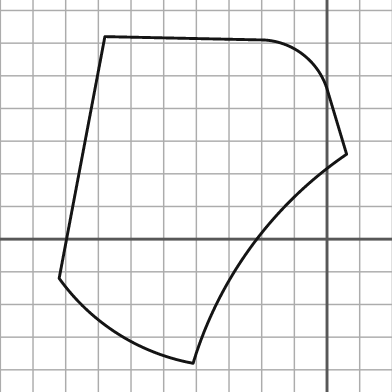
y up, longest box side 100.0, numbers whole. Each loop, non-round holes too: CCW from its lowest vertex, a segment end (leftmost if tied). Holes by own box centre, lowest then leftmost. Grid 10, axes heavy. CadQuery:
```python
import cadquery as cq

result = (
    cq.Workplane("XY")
    .moveTo(-41.0, -38.0)
    .threePointArc((-23.0, -2.0), (6.0, 26.0))
    .lineTo(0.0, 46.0)
    .threePointArc((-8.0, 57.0), (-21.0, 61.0))
    .lineTo(-68.0, 62.0)
    .lineTo(-82.0, -12.0)
    .threePointArc((-64.0, -29.0), (-41.0, -38.0))
    .close()
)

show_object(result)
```